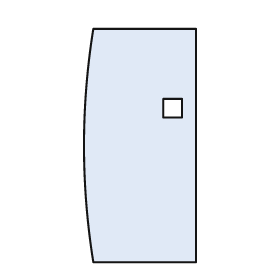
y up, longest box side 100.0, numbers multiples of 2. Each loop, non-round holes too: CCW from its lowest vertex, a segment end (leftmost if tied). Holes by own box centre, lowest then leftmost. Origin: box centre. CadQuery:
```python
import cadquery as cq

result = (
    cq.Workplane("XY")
    .moveTo(-20.0, -50.0)
    .lineTo(24.0, -50.0)
    .lineTo(24.0, 50.0)
    .lineTo(-20.0, 50.0)
    .threePointArc((-24.0, 0.0), (-20.0, -50.0))
    .close()
    .moveTo(10.0, 12.0)
    .lineTo(18.0, 12.0)
    .lineTo(18.0, 20.0)
    .lineTo(10.0, 20.0)
    .close()
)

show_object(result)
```